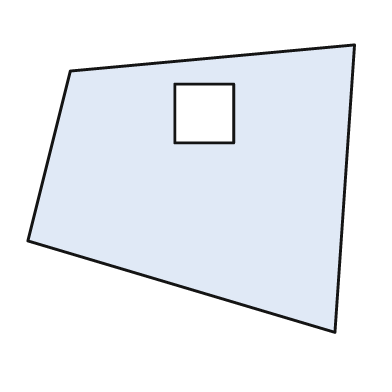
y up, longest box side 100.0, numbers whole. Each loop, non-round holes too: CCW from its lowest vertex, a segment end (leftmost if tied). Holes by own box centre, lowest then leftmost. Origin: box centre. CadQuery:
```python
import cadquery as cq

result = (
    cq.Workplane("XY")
    .moveTo(44.0, -44.0)
    .lineTo(50.0, 44.0)
    .lineTo(-37.0, 36.0)
    .lineTo(-50.0, -16.0)
    .close()
    .moveTo(-5.0, 14.0)
    .lineTo(13.0, 14.0)
    .lineTo(13.0, 32.0)
    .lineTo(-5.0, 32.0)
    .close()
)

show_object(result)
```